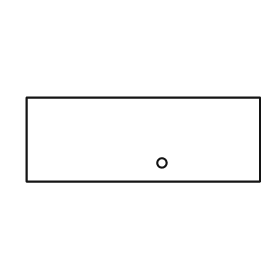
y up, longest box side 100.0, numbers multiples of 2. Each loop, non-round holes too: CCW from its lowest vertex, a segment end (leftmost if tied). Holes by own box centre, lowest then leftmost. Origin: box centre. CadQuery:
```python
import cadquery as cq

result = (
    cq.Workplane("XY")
    .moveTo(-50.0, -18.0)
    .lineTo(50.0, -18.0)
    .lineTo(50.0, 18.0)
    .lineTo(-50.0, 18.0)
    .close()
    .moveTo(8.0, -10.0)
    .circle(2.0)
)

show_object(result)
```